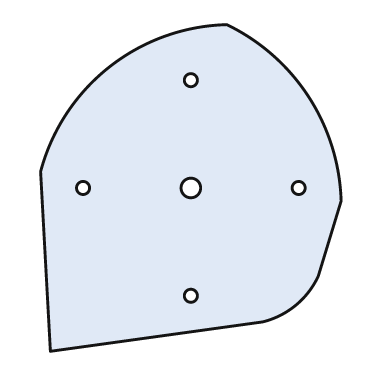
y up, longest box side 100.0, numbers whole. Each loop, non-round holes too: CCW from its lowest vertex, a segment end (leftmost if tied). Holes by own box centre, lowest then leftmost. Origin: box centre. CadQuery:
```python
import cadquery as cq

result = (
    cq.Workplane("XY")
    .moveTo(-43.0, -50.0)
    .lineTo(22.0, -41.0)
    .threePointArc((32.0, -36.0), (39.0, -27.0))
    .lineTo(46.0, -4.0)
    .threePointArc((36.0, 28.0), (11.0, 50.0))
    .threePointArc((-25.0, 37.0), (-46.0, 5.0))
    .close()
    .moveTo(0.0, -33.0)
    .circle(2.0)
    .moveTo(-33.0, 0.0)
    .circle(2.0)
    .moveTo(0.0, 0.0)
    .circle(3.0)
    .moveTo(33.0, 0.0)
    .circle(2.0)
    .moveTo(0.0, 33.0)
    .circle(2.0)
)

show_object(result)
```